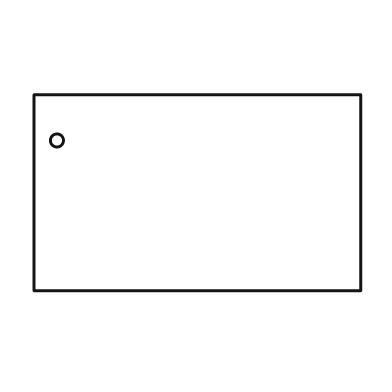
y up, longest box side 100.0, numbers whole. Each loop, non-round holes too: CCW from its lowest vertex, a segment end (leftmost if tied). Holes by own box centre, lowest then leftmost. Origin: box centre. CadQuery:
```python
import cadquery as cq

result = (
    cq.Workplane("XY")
    .moveTo(-50.0, -30.0)
    .lineTo(50.0, -30.0)
    .lineTo(50.0, 30.0)
    .lineTo(-50.0, 30.0)
    .close()
    .moveTo(-43.0, 16.0)
    .circle(2.0)
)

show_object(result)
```